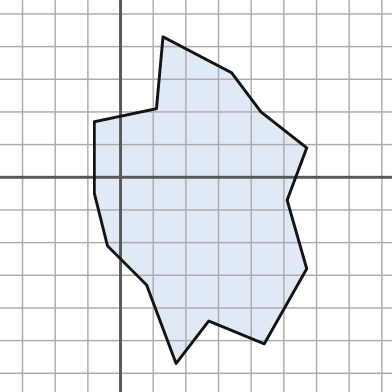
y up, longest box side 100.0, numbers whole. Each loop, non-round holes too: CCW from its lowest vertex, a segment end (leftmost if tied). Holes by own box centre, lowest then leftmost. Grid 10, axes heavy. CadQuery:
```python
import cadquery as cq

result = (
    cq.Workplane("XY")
    .moveTo(17.0, -57.0)
    .lineTo(27.0, -44.0)
    .lineTo(44.0, -51.0)
    .lineTo(57.0, -28.0)
    .lineTo(51.0, -7.0)
    .lineTo(57.0, 9.0)
    .lineTo(43.0, 20.0)
    .lineTo(34.0, 32.0)
    .lineTo(13.0, 43.0)
    .lineTo(11.0, 21.0)
    .lineTo(-8.0, 17.0)
    .lineTo(-8.0, -5.0)
    .lineTo(-4.0, -21.0)
    .lineTo(8.0, -33.0)
    .close()
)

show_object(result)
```